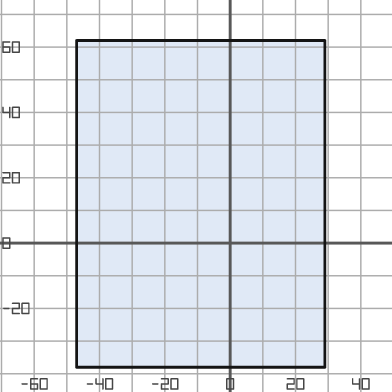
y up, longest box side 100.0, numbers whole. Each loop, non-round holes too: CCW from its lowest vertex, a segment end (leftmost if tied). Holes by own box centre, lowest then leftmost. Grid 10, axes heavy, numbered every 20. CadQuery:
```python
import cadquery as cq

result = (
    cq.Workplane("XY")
    .moveTo(-47.0, -38.0)
    .lineTo(29.0, -38.0)
    .lineTo(29.0, 62.0)
    .lineTo(-47.0, 62.0)
    .close()
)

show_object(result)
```